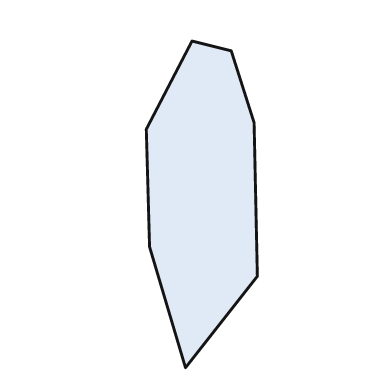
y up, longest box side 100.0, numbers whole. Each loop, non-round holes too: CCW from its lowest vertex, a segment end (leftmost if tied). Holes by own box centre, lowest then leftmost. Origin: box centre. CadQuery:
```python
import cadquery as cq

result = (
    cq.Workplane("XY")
    .moveTo(-5.0, -50.0)
    .lineTo(17.0, -22.0)
    .lineTo(16.0, 25.0)
    .lineTo(9.0, 47.0)
    .lineTo(-3.0, 50.0)
    .lineTo(-17.0, 23.0)
    .lineTo(-16.0, -13.0)
    .close()
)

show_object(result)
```